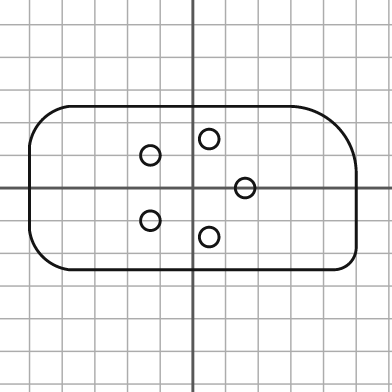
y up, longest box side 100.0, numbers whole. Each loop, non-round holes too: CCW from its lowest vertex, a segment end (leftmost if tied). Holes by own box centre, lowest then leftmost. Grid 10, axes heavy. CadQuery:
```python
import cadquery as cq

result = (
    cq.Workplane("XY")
    .moveTo(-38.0, -25.0)
    .lineTo(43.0, -25.0)
    .threePointArc((48.0, -23.0), (50.0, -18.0))
    .lineTo(50.0, 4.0)
    .threePointArc((44.0, 19.0), (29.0, 25.0))
    .lineTo(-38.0, 25.0)
    .threePointArc((-46.0, 21.0), (-50.0, 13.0))
    .lineTo(-50.0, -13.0)
    .threePointArc((-46.0, -21.0), (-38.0, -25.0))
    .close()
    .moveTo(5.0, -15.0)
    .circle(3.0)
    .moveTo(-13.0, -10.0)
    .circle(3.0)
    .moveTo(16.0, 0.0)
    .circle(3.0)
    .moveTo(-13.0, 10.0)
    .circle(3.0)
    .moveTo(5.0, 15.0)
    .circle(3.0)
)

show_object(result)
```